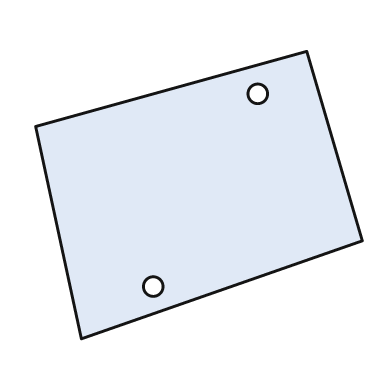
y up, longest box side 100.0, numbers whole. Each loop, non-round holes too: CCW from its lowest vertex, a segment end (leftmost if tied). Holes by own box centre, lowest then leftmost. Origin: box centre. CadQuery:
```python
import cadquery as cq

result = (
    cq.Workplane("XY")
    .moveTo(-36.0, -44.0)
    .lineTo(50.0, -14.0)
    .lineTo(33.0, 44.0)
    .lineTo(-50.0, 21.0)
    .close()
    .moveTo(-14.0, -28.0)
    .circle(3.0)
    .moveTo(18.0, 31.0)
    .circle(3.0)
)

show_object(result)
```